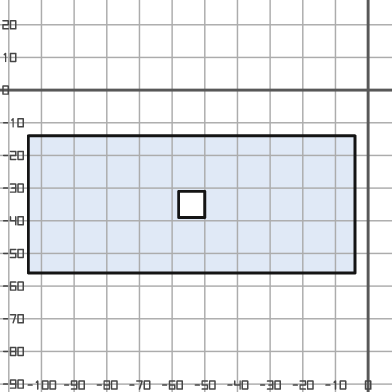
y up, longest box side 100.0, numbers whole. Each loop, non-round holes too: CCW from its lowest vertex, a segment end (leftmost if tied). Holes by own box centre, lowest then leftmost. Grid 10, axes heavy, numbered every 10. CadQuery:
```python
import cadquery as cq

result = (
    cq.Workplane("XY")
    .moveTo(-104.0, -56.0)
    .lineTo(-4.0, -56.0)
    .lineTo(-4.0, -14.0)
    .lineTo(-104.0, -14.0)
    .close()
    .moveTo(-58.0, -39.0)
    .lineTo(-50.0, -39.0)
    .lineTo(-50.0, -31.0)
    .lineTo(-58.0, -31.0)
    .close()
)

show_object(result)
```